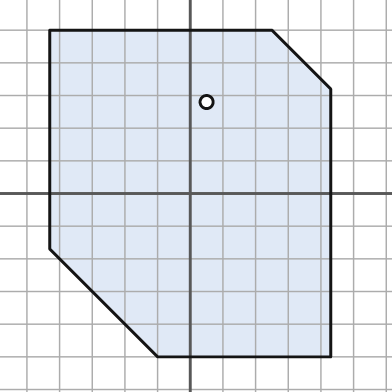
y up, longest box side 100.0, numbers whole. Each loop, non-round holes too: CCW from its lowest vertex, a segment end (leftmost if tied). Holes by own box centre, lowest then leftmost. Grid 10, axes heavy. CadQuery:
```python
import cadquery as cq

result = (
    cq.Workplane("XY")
    .moveTo(-10.0, -50.0)
    .lineTo(43.0, -50.0)
    .lineTo(43.0, 32.0)
    .lineTo(25.0, 50.0)
    .lineTo(-43.0, 50.0)
    .lineTo(-43.0, -17.0)
    .close()
    .moveTo(5.0, 28.0)
    .circle(2.0)
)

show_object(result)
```